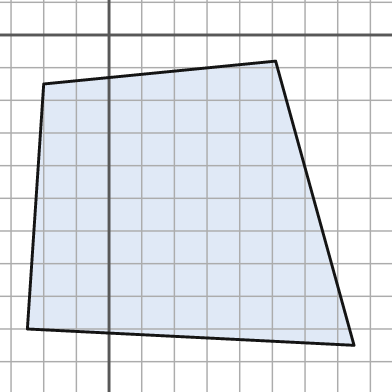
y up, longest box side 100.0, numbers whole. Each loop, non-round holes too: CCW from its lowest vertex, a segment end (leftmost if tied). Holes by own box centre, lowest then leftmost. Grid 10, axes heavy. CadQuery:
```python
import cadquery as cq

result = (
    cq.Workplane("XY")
    .moveTo(75.0, -95.0)
    .lineTo(51.0, -8.0)
    .lineTo(-20.0, -15.0)
    .lineTo(-25.0, -90.0)
    .close()
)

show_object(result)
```